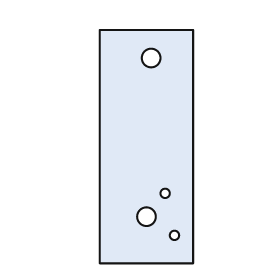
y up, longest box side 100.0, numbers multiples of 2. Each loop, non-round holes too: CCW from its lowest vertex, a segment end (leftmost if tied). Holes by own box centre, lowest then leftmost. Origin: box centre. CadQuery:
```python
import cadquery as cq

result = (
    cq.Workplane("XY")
    .moveTo(-20.0, -50.0)
    .lineTo(20.0, -50.0)
    .lineTo(20.0, 50.0)
    .lineTo(-20.0, 50.0)
    .close()
    .moveTo(12.0, -38.0)
    .circle(2.0)
    .moveTo(0.0, -30.0)
    .circle(4.0)
    .moveTo(8.0, -20.0)
    .circle(2.0)
    .moveTo(2.0, 38.0)
    .circle(4.0)
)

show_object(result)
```